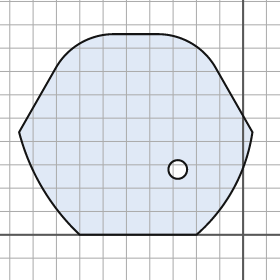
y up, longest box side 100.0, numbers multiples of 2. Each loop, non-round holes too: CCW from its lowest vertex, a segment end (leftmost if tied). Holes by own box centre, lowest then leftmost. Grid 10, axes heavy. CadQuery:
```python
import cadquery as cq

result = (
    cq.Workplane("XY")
    .moveTo(-70.0, 0.0)
    .lineTo(-20.0, 0.0)
    .threePointArc((-4.0, 20.0), (4.0, 44.0))
    .lineTo(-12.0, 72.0)
    .threePointArc((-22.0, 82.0), (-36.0, 86.0))
    .lineTo(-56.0, 86.0)
    .threePointArc((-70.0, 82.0), (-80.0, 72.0))
    .lineTo(-96.0, 44.0)
    .threePointArc((-86.0, 20.0), (-70.0, 0.0))
    .close()
    .moveTo(-28.0, 28.0)
    .circle(4.0)
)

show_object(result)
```